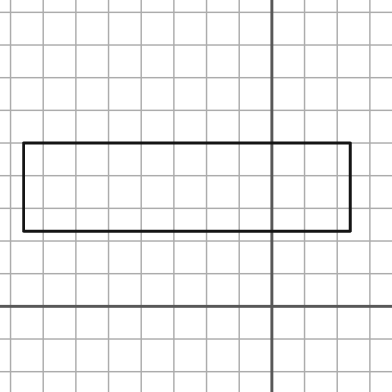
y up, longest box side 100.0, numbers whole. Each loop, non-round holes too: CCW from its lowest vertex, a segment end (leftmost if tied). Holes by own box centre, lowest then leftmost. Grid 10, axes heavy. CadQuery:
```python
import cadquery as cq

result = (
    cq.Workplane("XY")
    .moveTo(-76.0, 23.0)
    .lineTo(24.0, 23.0)
    .lineTo(24.0, 50.0)
    .lineTo(-76.0, 50.0)
    .close()
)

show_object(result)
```